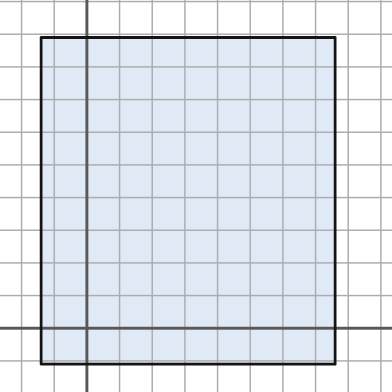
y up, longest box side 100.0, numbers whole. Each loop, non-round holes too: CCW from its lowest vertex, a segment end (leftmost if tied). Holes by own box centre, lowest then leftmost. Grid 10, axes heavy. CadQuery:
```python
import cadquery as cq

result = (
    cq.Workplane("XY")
    .moveTo(-14.0, -11.0)
    .lineTo(76.0, -11.0)
    .lineTo(76.0, 89.0)
    .lineTo(-14.0, 89.0)
    .close()
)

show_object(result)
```